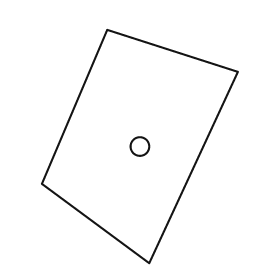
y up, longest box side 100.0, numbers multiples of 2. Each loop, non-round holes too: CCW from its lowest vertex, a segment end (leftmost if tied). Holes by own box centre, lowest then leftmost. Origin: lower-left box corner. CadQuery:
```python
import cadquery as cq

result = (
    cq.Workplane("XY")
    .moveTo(46.0, 0.0)
    .lineTo(84.0, 82.0)
    .lineTo(28.0, 100.0)
    .lineTo(0.0, 34.0)
    .close()
    .moveTo(42.0, 50.0)
    .circle(4.0)
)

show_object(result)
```